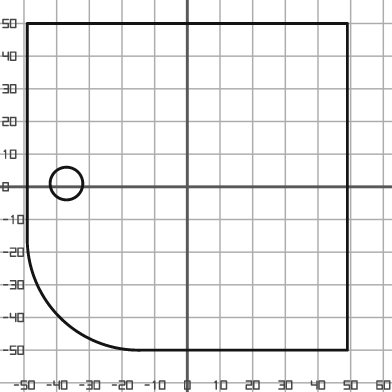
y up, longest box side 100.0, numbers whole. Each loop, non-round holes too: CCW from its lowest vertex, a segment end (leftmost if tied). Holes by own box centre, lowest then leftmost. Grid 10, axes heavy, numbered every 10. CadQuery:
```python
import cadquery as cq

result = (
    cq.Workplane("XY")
    .moveTo(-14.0, -50.0)
    .lineTo(49.0, -50.0)
    .lineTo(49.0, 50.0)
    .lineTo(-49.0, 50.0)
    .lineTo(-49.0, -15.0)
    .threePointArc((-39.0, -40.0), (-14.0, -50.0))
    .close()
    .moveTo(-37.0, 1.0)
    .circle(5.0)
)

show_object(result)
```